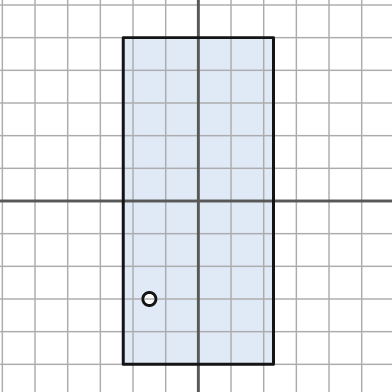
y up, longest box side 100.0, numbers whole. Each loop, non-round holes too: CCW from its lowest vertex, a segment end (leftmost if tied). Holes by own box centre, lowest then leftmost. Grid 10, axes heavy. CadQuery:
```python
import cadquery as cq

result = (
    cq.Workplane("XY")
    .moveTo(-23.0, -50.0)
    .lineTo(23.0, -50.0)
    .lineTo(23.0, 50.0)
    .lineTo(-23.0, 50.0)
    .close()
    .moveTo(-15.0, -30.0)
    .circle(2.0)
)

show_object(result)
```